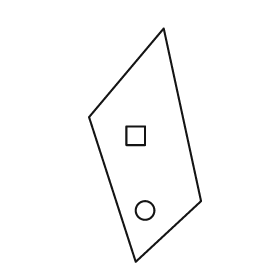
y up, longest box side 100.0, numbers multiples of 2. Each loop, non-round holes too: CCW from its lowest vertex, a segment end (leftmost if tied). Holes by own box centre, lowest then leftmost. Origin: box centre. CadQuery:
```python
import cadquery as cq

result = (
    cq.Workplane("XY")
    .moveTo(-4.0, -50.0)
    .lineTo(24.0, -24.0)
    .lineTo(8.0, 50.0)
    .lineTo(-24.0, 12.0)
    .close()
    .moveTo(0.0, -28.0)
    .circle(4.0)
    .moveTo(-8.0, 0.0)
    .lineTo(0.0, 0.0)
    .lineTo(0.0, 8.0)
    .lineTo(-8.0, 8.0)
    .close()
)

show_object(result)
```